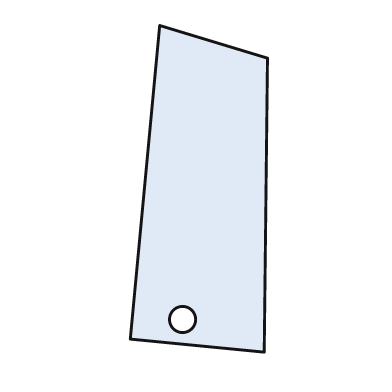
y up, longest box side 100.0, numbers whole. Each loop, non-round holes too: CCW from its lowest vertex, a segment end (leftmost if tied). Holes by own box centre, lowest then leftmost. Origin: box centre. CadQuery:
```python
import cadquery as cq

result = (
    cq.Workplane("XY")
    .moveTo(20.0, -50.0)
    .lineTo(21.0, 40.0)
    .lineTo(-12.0, 50.0)
    .lineTo(-21.0, -46.0)
    .close()
    .moveTo(-5.0, -40.0)
    .circle(4.0)
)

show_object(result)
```